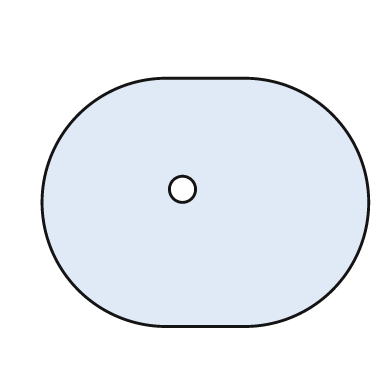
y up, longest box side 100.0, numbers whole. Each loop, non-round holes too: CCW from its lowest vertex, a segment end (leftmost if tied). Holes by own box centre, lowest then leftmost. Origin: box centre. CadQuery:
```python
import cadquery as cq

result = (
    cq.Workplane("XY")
    .moveTo(-12.0, -38.0)
    .lineTo(12.0, -38.0)
    .threePointArc((50.0, 0.0), (12.0, 38.0))
    .lineTo(-12.0, 38.0)
    .threePointArc((-50.0, 0.0), (-12.0, -38.0))
    .close()
    .moveTo(-7.0, 4.0)
    .circle(4.0)
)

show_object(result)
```